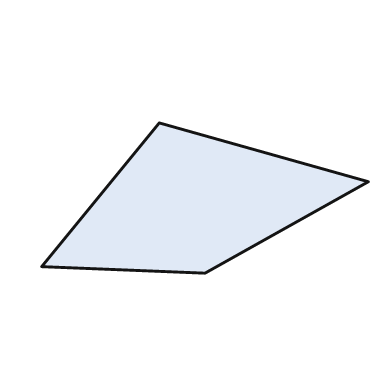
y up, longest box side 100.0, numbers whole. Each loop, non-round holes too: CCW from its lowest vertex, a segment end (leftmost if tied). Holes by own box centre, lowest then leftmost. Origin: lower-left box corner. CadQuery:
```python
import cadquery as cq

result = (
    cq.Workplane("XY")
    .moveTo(50.0, 0.0)
    .lineTo(100.0, 28.0)
    .lineTo(36.0, 46.0)
    .lineTo(0.0, 2.0)
    .close()
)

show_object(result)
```